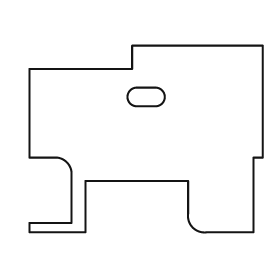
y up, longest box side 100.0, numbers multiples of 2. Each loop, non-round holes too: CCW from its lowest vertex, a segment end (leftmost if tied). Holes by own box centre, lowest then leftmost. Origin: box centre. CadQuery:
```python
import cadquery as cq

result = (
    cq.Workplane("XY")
    .moveTo(-50.0, -40.0)
    .lineTo(-26.0, -40.0)
    .lineTo(-26.0, -18.0)
    .lineTo(18.0, -18.0)
    .lineTo(18.0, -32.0)
    .threePointArc((20.0, -38.0), (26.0, -40.0))
    .lineTo(46.0, -40.0)
    .lineTo(46.0, -8.0)
    .lineTo(50.0, -8.0)
    .lineTo(50.0, 40.0)
    .lineTo(-6.0, 40.0)
    .lineTo(-6.0, 30.0)
    .lineTo(-50.0, 30.0)
    .lineTo(-50.0, -8.0)
    .lineTo(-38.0, -8.0)
    .threePointArc((-34.0, -10.0), (-32.0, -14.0))
    .lineTo(-32.0, -36.0)
    .lineTo(-50.0, -36.0)
    .close()
    .moveTo(-4.0, 14.0)
    .lineTo(4.0, 14.0)
    .threePointArc((8.0, 18.0), (4.0, 22.0))
    .lineTo(-4.0, 22.0)
    .threePointArc((-8.0, 18.0), (-4.0, 14.0))
    .close()
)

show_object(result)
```